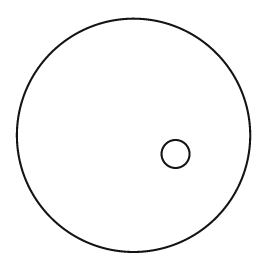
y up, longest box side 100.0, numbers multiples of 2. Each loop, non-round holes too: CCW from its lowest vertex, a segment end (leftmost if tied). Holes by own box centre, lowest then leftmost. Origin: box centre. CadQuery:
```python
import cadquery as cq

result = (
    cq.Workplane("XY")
    .moveTo(0.0, 0.0)
    .circle(50.0)
    .moveTo(18.0, -8.0)
    .circle(6.0)
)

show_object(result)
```